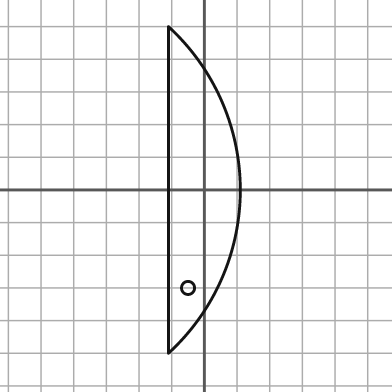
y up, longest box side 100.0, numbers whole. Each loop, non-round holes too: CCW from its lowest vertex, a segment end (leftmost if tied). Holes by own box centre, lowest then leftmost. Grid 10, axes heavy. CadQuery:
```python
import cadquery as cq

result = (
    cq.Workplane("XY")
    .moveTo(-11.0, -50.0)
    .threePointArc((11.0, 0.0), (-11.0, 50.0))
    .close()
    .moveTo(-5.0, -30.0)
    .circle(2.0)
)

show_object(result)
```